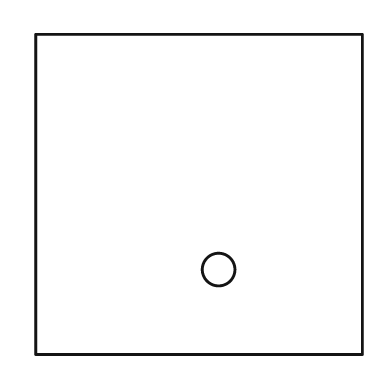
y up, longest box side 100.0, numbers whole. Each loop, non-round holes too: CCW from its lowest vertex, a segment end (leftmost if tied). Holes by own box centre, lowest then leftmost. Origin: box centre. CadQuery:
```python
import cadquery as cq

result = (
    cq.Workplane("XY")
    .moveTo(-50.0, -49.0)
    .lineTo(50.0, -49.0)
    .lineTo(50.0, 49.0)
    .lineTo(-50.0, 49.0)
    .close()
    .moveTo(6.0, -23.0)
    .circle(5.0)
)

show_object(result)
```